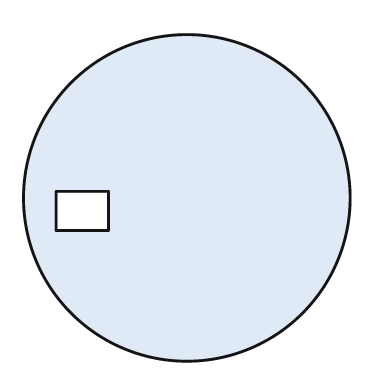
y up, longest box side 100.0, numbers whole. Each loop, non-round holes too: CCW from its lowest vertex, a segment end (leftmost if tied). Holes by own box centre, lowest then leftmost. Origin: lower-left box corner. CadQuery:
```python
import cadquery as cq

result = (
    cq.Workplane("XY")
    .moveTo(50.0, 50.0)
    .circle(50.0)
    .moveTo(10.0, 40.0)
    .lineTo(26.0, 40.0)
    .lineTo(26.0, 52.0)
    .lineTo(10.0, 52.0)
    .close()
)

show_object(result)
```